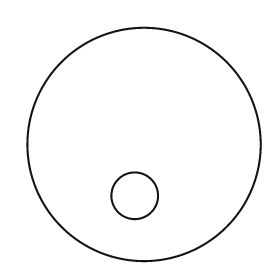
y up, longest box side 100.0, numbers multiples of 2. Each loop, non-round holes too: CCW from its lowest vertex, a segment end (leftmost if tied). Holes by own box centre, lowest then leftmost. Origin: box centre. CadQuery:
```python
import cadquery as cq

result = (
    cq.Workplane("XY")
    .moveTo(0.0, 0.0)
    .circle(50.0)
    .moveTo(-4.0, -22.0)
    .circle(10.0)
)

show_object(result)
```